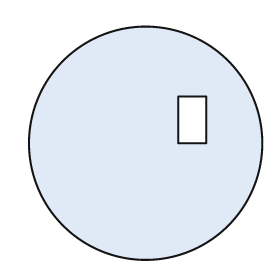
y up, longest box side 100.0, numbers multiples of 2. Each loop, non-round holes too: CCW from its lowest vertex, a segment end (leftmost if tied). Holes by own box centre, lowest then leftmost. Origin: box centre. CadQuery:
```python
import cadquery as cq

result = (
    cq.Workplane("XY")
    .moveTo(0.0, 0.0)
    .circle(50.0)
    .moveTo(14.0, 0.0)
    .lineTo(26.0, 0.0)
    .lineTo(26.0, 20.0)
    .lineTo(14.0, 20.0)
    .close()
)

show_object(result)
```